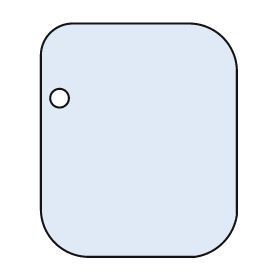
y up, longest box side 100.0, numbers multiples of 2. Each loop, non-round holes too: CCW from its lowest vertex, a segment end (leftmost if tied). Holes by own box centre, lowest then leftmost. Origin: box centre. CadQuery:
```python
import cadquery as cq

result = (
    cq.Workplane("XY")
    .moveTo(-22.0, -50.0)
    .lineTo(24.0, -50.0)
    .threePointArc((36.0, -44.0), (42.0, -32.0))
    .lineTo(42.0, 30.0)
    .threePointArc((36.0, 44.0), (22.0, 50.0))
    .lineTo(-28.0, 50.0)
    .threePointArc((-38.0, 46.0), (-42.0, 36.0))
    .lineTo(-42.0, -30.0)
    .threePointArc((-36.0, -44.0), (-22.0, -50.0))
    .close()
    .moveTo(-34.0, 18.0)
    .circle(4.0)
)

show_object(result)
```